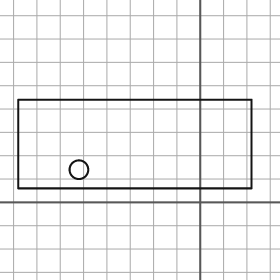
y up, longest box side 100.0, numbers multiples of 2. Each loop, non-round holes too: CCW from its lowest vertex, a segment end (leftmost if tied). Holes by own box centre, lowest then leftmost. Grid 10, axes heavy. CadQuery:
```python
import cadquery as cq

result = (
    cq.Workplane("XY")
    .moveTo(-78.0, 6.0)
    .lineTo(22.0, 6.0)
    .lineTo(22.0, 44.0)
    .lineTo(-78.0, 44.0)
    .close()
    .moveTo(-52.0, 14.0)
    .circle(4.0)
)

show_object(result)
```